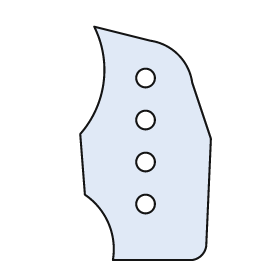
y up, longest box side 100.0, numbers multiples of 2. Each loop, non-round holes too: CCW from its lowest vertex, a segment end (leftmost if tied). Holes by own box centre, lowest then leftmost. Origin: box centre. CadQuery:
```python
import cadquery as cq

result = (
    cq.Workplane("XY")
    .moveTo(-14.0, -50.0)
    .lineTo(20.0, -50.0)
    .threePointArc((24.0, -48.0), (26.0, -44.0))
    .lineTo(28.0, 2.0)
    .lineTo(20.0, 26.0)
    .threePointArc((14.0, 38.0), (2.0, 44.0))
    .lineTo(-22.0, 50.0)
    .threePointArc((-18.0, 26.0), (-28.0, 4.0))
    .lineTo(-26.0, -22.0)
    .threePointArc((-16.0, -34.0), (-14.0, -50.0))
    .close()
    .moveTo(0.0, -26.0)
    .circle(4.0)
    .moveTo(0.0, -8.0)
    .circle(4.0)
    .moveTo(0.0, 10.0)
    .circle(4.0)
    .moveTo(0.0, 28.0)
    .circle(4.0)
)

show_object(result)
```